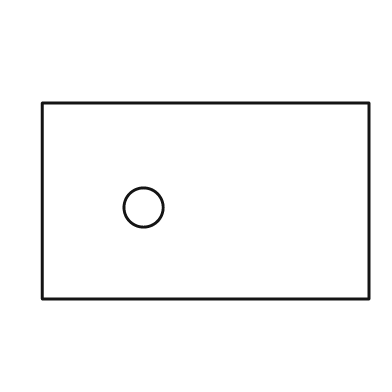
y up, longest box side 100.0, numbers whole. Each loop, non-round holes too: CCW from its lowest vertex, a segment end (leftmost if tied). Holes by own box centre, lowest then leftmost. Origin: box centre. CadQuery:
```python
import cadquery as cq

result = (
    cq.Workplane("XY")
    .moveTo(-50.0, -30.0)
    .lineTo(50.0, -30.0)
    .lineTo(50.0, 30.0)
    .lineTo(-50.0, 30.0)
    .close()
    .moveTo(-19.0, -2.0)
    .circle(6.0)
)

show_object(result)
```